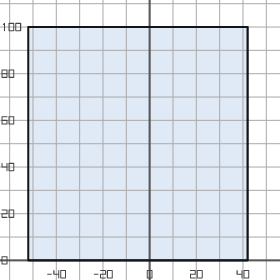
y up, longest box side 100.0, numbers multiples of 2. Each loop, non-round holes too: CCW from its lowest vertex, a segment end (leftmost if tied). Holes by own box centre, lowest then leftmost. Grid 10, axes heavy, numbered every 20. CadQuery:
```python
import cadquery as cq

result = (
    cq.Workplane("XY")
    .moveTo(-52.0, 0.0)
    .lineTo(42.0, 0.0)
    .lineTo(42.0, 100.0)
    .lineTo(-52.0, 100.0)
    .close()
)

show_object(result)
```